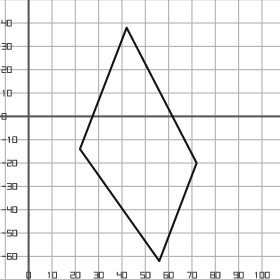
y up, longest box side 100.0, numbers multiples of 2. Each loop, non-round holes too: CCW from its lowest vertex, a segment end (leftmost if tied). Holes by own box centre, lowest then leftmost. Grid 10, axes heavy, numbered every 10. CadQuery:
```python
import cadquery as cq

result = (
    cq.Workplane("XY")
    .moveTo(56.0, -62.0)
    .lineTo(72.0, -20.0)
    .lineTo(42.0, 38.0)
    .lineTo(22.0, -14.0)
    .close()
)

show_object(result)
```